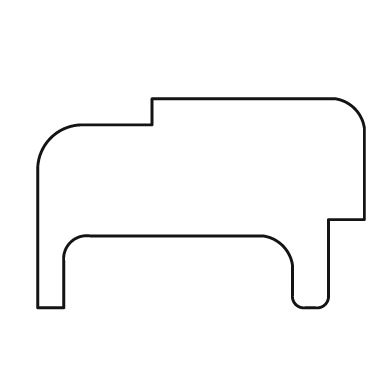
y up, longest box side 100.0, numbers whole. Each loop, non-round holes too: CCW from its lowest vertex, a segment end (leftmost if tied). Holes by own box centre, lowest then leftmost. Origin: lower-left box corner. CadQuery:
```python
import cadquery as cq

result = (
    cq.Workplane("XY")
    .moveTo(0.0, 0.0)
    .lineTo(8.0, 0.0)
    .lineTo(8.0, 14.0)
    .threePointArc((10.0, 20.0), (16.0, 22.0))
    .lineTo(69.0, 22.0)
    .threePointArc((75.0, 19.0), (78.0, 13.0))
    .lineTo(78.0, 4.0)
    .threePointArc((79.0, 1.0), (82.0, 0.0))
    .lineTo(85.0, 0.0)
    .threePointArc((88.0, 1.0), (89.0, 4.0))
    .lineTo(89.0, 27.0)
    .lineTo(100.0, 27.0)
    .lineTo(100.0, 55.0)
    .threePointArc((97.0, 61.0), (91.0, 64.0))
    .lineTo(35.0, 64.0)
    .lineTo(35.0, 56.0)
    .lineTo(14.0, 56.0)
    .threePointArc((4.0, 52.0), (0.0, 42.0))
    .close()
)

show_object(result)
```